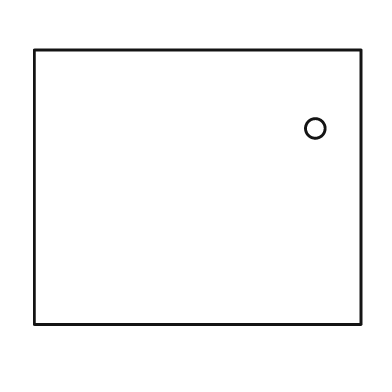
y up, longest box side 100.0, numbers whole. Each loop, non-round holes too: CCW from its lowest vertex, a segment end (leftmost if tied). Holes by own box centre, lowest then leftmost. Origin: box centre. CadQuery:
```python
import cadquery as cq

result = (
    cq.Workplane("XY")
    .moveTo(-50.0, -42.0)
    .lineTo(50.0, -42.0)
    .lineTo(50.0, 42.0)
    .lineTo(-50.0, 42.0)
    .close()
    .moveTo(36.0, 18.0)
    .circle(3.0)
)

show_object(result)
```